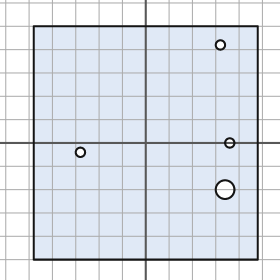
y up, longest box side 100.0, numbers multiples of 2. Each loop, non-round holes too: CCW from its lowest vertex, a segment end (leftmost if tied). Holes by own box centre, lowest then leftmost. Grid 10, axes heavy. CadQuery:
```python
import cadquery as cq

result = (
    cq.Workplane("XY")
    .moveTo(-48.0, -50.0)
    .lineTo(48.0, -50.0)
    .lineTo(48.0, 50.0)
    .lineTo(-48.0, 50.0)
    .close()
    .moveTo(34.0, -20.0)
    .circle(4.0)
    .moveTo(-28.0, -4.0)
    .circle(2.0)
    .moveTo(36.0, 0.0)
    .circle(2.0)
    .moveTo(32.0, 42.0)
    .circle(2.0)
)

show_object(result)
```